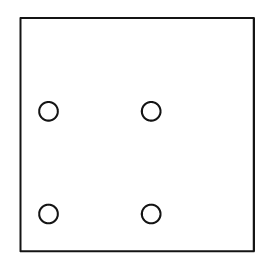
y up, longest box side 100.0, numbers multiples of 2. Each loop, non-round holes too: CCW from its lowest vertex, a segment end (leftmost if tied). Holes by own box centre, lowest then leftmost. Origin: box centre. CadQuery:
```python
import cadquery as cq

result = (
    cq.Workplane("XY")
    .moveTo(-50.0, -50.0)
    .lineTo(50.0, -50.0)
    .lineTo(50.0, 50.0)
    .lineTo(-50.0, 50.0)
    .close()
    .moveTo(-38.0, -34.0)
    .circle(4.0)
    .moveTo(6.0, -34.0)
    .circle(4.0)
    .moveTo(-38.0, 10.0)
    .circle(4.0)
    .moveTo(6.0, 10.0)
    .circle(4.0)
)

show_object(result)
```